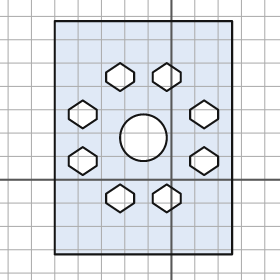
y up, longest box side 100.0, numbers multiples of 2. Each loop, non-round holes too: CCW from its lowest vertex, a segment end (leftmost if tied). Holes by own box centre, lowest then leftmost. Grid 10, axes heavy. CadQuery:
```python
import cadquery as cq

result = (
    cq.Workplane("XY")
    .moveTo(-50.0, -32.0)
    .lineTo(26.0, -32.0)
    .lineTo(26.0, 68.0)
    .lineTo(-50.0, 68.0)
    .close()
    .moveTo(-22.0, -14.0)
    .lineTo(-16.0, -10.0)
    .lineTo(-16.0, -6.0)
    .lineTo(-22.0, -2.0)
    .lineTo(-28.0, -6.0)
    .lineTo(-28.0, -10.0)
    .close()
    .moveTo(-2.0, -14.0)
    .lineTo(4.0, -10.0)
    .lineTo(4.0, -6.0)
    .lineTo(-2.0, -2.0)
    .lineTo(-8.0, -6.0)
    .lineTo(-8.0, -10.0)
    .close()
    .moveTo(-38.0, 2.0)
    .lineTo(-32.0, 6.0)
    .lineTo(-32.0, 10.0)
    .lineTo(-38.0, 14.0)
    .lineTo(-44.0, 10.0)
    .lineTo(-44.0, 6.0)
    .close()
    .moveTo(14.0, 2.0)
    .lineTo(20.0, 6.0)
    .lineTo(20.0, 10.0)
    .lineTo(14.0, 14.0)
    .lineTo(8.0, 10.0)
    .lineTo(8.0, 6.0)
    .close()
    .moveTo(-12.0, 18.0)
    .circle(10.0)
    .moveTo(-38.0, 22.0)
    .lineTo(-32.0, 26.0)
    .lineTo(-32.0, 30.0)
    .lineTo(-38.0, 34.0)
    .lineTo(-44.0, 30.0)
    .lineTo(-44.0, 26.0)
    .close()
    .moveTo(14.0, 22.0)
    .lineTo(20.0, 26.0)
    .lineTo(20.0, 30.0)
    .lineTo(14.0, 34.0)
    .lineTo(8.0, 30.0)
    .lineTo(8.0, 26.0)
    .close()
    .moveTo(-22.0, 38.0)
    .lineTo(-16.0, 42.0)
    .lineTo(-16.0, 46.0)
    .lineTo(-22.0, 50.0)
    .lineTo(-28.0, 46.0)
    .lineTo(-28.0, 42.0)
    .close()
    .moveTo(-2.0, 38.0)
    .lineTo(4.0, 42.0)
    .lineTo(4.0, 46.0)
    .lineTo(-2.0, 50.0)
    .lineTo(-8.0, 46.0)
    .lineTo(-8.0, 42.0)
    .close()
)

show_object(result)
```